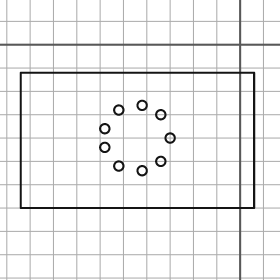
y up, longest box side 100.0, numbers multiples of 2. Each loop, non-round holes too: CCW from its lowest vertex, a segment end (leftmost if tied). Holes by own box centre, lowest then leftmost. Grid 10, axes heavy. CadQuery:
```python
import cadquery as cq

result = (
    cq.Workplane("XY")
    .moveTo(-94.0, -70.0)
    .lineTo(6.0, -70.0)
    .lineTo(6.0, -12.0)
    .lineTo(-94.0, -12.0)
    .close()
    .moveTo(-42.0, -54.0)
    .circle(2.0)
    .moveTo(-52.0, -52.0)
    .circle(2.0)
    .moveTo(-34.0, -50.0)
    .circle(2.0)
    .moveTo(-58.0, -44.0)
    .circle(2.0)
    .moveTo(-30.0, -40.0)
    .circle(2.0)
    .moveTo(-58.0, -36.0)
    .circle(2.0)
    .moveTo(-34.0, -30.0)
    .circle(2.0)
    .moveTo(-52.0, -28.0)
    .circle(2.0)
    .moveTo(-42.0, -26.0)
    .circle(2.0)
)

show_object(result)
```